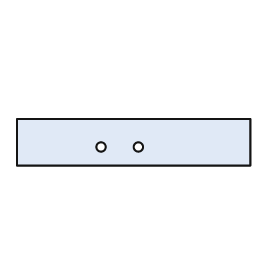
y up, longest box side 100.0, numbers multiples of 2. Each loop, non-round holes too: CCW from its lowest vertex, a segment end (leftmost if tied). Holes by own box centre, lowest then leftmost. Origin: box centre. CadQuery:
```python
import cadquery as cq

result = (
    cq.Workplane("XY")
    .moveTo(-50.0, -10.0)
    .lineTo(50.0, -10.0)
    .lineTo(50.0, 10.0)
    .lineTo(-50.0, 10.0)
    .close()
    .moveTo(-14.0, -2.0)
    .circle(2.0)
    .moveTo(2.0, -2.0)
    .circle(2.0)
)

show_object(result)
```